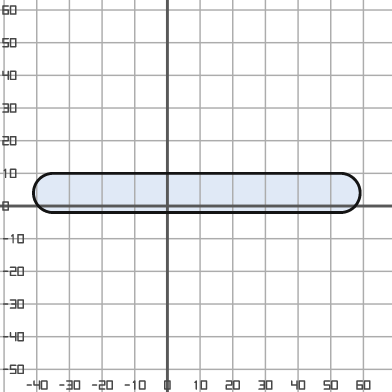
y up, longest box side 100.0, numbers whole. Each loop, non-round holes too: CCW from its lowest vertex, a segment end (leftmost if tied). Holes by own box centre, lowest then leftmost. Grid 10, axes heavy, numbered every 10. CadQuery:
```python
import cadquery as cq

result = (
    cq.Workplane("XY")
    .moveTo(-35.0, -2.0)
    .lineTo(53.0, -2.0)
    .threePointArc((59.0, 4.0), (53.0, 10.0))
    .lineTo(-35.0, 10.0)
    .threePointArc((-41.0, 4.0), (-35.0, -2.0))
    .close()
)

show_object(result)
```